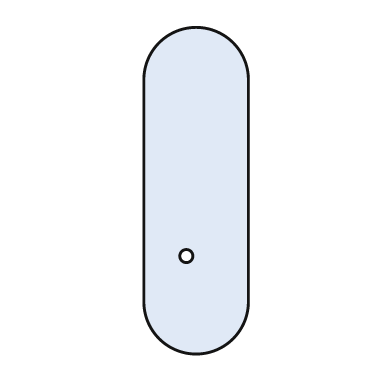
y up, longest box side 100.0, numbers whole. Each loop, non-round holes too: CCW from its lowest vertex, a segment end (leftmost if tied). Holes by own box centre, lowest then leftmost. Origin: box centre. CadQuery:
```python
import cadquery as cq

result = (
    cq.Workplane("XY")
    .moveTo(-16.0, -34.0)
    .threePointArc((0.0, -50.0), (16.0, -34.0))
    .lineTo(16.0, 34.0)
    .threePointArc((0.0, 50.0), (-16.0, 34.0))
    .close()
    .moveTo(-3.0, -20.0)
    .circle(2.0)
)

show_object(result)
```